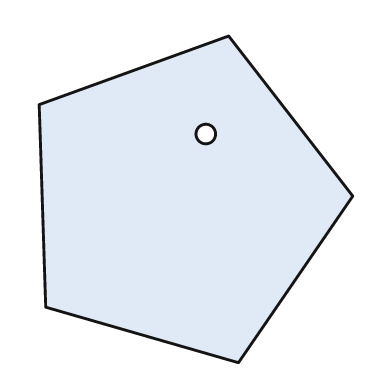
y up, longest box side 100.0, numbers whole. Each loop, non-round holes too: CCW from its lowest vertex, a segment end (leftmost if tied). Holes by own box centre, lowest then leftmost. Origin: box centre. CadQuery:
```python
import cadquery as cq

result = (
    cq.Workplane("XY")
    .moveTo(13.0, -50.0)
    .lineTo(48.0, 1.0)
    .lineTo(10.0, 50.0)
    .lineTo(-48.0, 29.0)
    .lineTo(-46.0, -33.0)
    .close()
    .moveTo(3.0, 20.0)
    .circle(3.0)
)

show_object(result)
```